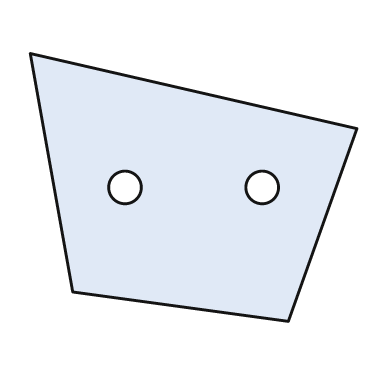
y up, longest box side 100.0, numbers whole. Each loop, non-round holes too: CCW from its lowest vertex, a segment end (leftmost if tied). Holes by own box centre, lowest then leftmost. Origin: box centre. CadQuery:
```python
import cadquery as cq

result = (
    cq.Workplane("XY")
    .moveTo(29.0, -41.0)
    .lineTo(50.0, 18.0)
    .lineTo(-50.0, 41.0)
    .lineTo(-37.0, -32.0)
    .close()
    .moveTo(-21.0, 0.0)
    .circle(5.0)
    .moveTo(21.0, 0.0)
    .circle(5.0)
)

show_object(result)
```